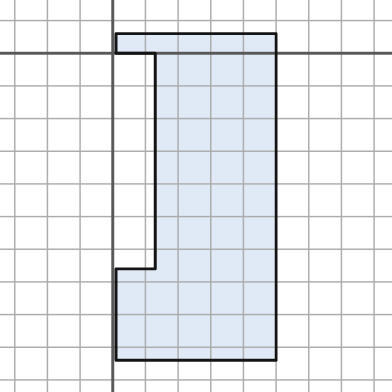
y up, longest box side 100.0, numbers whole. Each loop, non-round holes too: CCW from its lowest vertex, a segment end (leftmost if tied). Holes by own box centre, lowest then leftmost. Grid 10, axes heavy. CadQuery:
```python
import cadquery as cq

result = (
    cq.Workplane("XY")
    .moveTo(1.0, -94.0)
    .lineTo(50.0, -94.0)
    .lineTo(50.0, 6.0)
    .lineTo(1.0, 6.0)
    .lineTo(1.0, 0.0)
    .lineTo(13.0, 0.0)
    .lineTo(13.0, -66.0)
    .lineTo(1.0, -66.0)
    .close()
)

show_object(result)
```